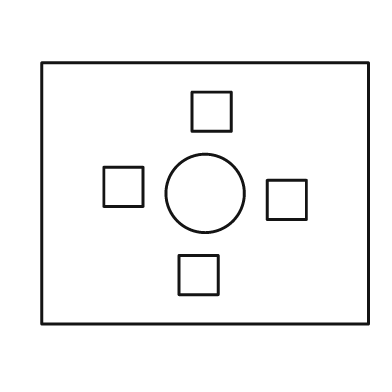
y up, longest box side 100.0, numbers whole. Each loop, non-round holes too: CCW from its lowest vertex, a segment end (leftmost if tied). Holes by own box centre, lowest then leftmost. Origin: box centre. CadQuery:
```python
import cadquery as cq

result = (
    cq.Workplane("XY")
    .moveTo(-50.0, -40.0)
    .lineTo(50.0, -40.0)
    .lineTo(50.0, 40.0)
    .lineTo(-50.0, 40.0)
    .close()
    .moveTo(-8.0, -31.0)
    .lineTo(4.0, -31.0)
    .lineTo(4.0, -19.0)
    .lineTo(-8.0, -19.0)
    .close()
    .moveTo(19.0, -8.0)
    .lineTo(31.0, -8.0)
    .lineTo(31.0, 4.0)
    .lineTo(19.0, 4.0)
    .close()
    .moveTo(0.0, 0.0)
    .circle(12.0)
    .moveTo(-31.0, -4.0)
    .lineTo(-19.0, -4.0)
    .lineTo(-19.0, 8.0)
    .lineTo(-31.0, 8.0)
    .close()
    .moveTo(-4.0, 19.0)
    .lineTo(8.0, 19.0)
    .lineTo(8.0, 31.0)
    .lineTo(-4.0, 31.0)
    .close()
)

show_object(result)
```